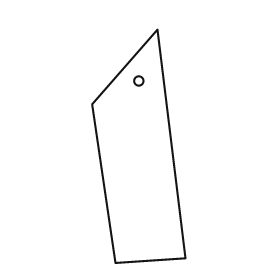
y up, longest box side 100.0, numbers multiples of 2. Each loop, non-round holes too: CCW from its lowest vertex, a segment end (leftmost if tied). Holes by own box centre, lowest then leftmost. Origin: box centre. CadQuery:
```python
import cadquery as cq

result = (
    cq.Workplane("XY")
    .moveTo(-10.0, -50.0)
    .lineTo(20.0, -48.0)
    .lineTo(8.0, 50.0)
    .lineTo(-20.0, 18.0)
    .close()
    .moveTo(0.0, 28.0)
    .circle(2.0)
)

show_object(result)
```